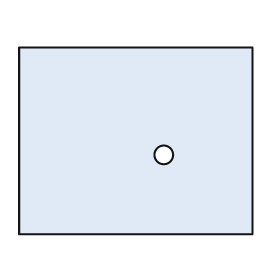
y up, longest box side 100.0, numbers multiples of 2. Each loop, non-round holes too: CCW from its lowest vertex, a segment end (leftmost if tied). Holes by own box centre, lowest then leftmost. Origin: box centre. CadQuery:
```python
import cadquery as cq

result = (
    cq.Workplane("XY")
    .moveTo(-50.0, -40.0)
    .lineTo(50.0, -40.0)
    .lineTo(50.0, 40.0)
    .lineTo(-50.0, 40.0)
    .close()
    .moveTo(12.0, -6.0)
    .circle(4.0)
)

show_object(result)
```